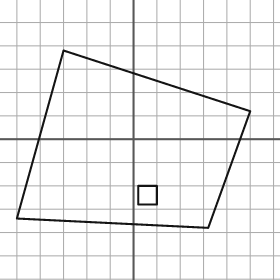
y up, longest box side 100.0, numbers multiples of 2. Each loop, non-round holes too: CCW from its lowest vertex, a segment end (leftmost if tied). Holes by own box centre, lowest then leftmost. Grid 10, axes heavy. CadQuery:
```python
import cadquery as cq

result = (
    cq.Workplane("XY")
    .moveTo(32.0, -38.0)
    .lineTo(50.0, 12.0)
    .lineTo(-30.0, 38.0)
    .lineTo(-50.0, -34.0)
    .close()
    .moveTo(2.0, -28.0)
    .lineTo(10.0, -28.0)
    .lineTo(10.0, -20.0)
    .lineTo(2.0, -20.0)
    .close()
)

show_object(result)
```